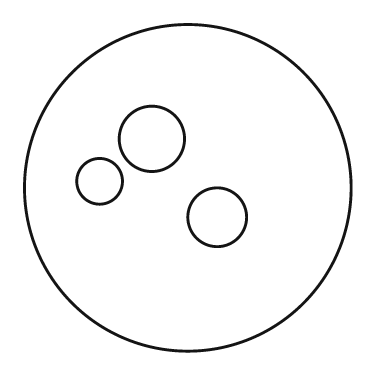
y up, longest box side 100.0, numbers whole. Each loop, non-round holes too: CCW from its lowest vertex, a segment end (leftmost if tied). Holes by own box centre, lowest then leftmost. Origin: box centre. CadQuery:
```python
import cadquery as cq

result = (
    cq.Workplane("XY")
    .moveTo(0.0, 0.0)
    .circle(50.0)
    .moveTo(9.0, -9.0)
    .circle(9.0)
    .moveTo(-27.0, 2.0)
    .circle(7.0)
    .moveTo(-11.0, 15.0)
    .circle(10.0)
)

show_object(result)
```